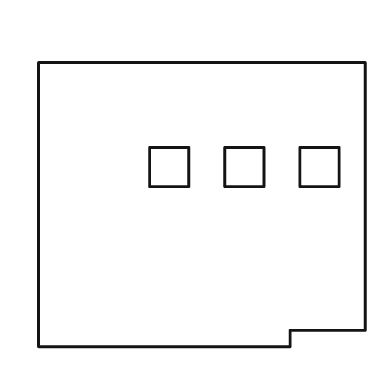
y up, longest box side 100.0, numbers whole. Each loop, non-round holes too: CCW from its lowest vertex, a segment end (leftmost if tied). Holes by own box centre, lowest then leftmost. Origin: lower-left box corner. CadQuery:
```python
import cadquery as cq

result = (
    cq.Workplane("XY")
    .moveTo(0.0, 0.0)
    .lineTo(77.0, 0.0)
    .lineTo(77.0, 5.0)
    .lineTo(100.0, 5.0)
    .lineTo(100.0, 87.0)
    .lineTo(0.0, 87.0)
    .close()
    .moveTo(34.0, 49.0)
    .lineTo(46.0, 49.0)
    .lineTo(46.0, 61.0)
    .lineTo(34.0, 61.0)
    .close()
    .moveTo(57.0, 49.0)
    .lineTo(69.0, 49.0)
    .lineTo(69.0, 61.0)
    .lineTo(57.0, 61.0)
    .close()
    .moveTo(80.0, 49.0)
    .lineTo(92.0, 49.0)
    .lineTo(92.0, 61.0)
    .lineTo(80.0, 61.0)
    .close()
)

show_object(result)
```